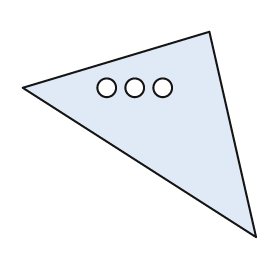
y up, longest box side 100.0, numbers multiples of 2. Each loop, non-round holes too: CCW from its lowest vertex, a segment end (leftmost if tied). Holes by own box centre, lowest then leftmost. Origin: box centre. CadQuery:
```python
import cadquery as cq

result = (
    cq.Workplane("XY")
    .moveTo(50.0, -44.0)
    .lineTo(30.0, 44.0)
    .lineTo(-50.0, 20.0)
    .close()
    .moveTo(-14.0, 20.0)
    .circle(4.0)
    .moveTo(-2.0, 20.0)
    .circle(4.0)
    .moveTo(10.0, 20.0)
    .circle(4.0)
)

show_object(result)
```